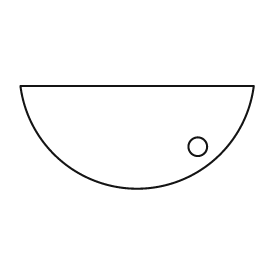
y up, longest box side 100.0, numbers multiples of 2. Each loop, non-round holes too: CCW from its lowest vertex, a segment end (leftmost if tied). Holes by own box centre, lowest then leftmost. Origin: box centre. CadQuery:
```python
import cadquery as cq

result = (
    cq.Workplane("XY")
    .moveTo(-50.0, 22.0)
    .threePointArc((0.0, -22.0), (50.0, 22.0))
    .close()
    .moveTo(26.0, -4.0)
    .circle(4.0)
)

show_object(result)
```